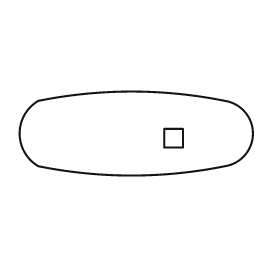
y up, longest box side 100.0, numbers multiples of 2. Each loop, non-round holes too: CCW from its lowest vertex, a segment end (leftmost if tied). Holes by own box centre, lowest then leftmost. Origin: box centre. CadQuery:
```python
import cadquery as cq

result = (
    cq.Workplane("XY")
    .moveTo(-42.0, -14.0)
    .threePointArc((-2.0, -18.0), (38.0, -14.0))
    .threePointArc((50.0, 0.0), (38.0, 14.0))
    .threePointArc((-2.0, 18.0), (-42.0, 14.0))
    .threePointArc((-50.0, 0.0), (-42.0, -14.0))
    .close()
    .moveTo(12.0, -6.0)
    .lineTo(20.0, -6.0)
    .lineTo(20.0, 2.0)
    .lineTo(12.0, 2.0)
    .close()
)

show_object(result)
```